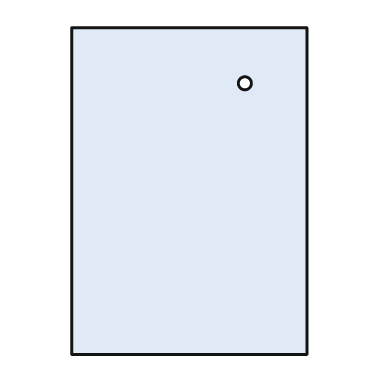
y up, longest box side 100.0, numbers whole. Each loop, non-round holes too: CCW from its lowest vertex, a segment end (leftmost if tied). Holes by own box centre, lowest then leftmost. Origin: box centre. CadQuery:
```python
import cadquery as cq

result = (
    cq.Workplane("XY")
    .moveTo(-36.0, -50.0)
    .lineTo(36.0, -50.0)
    .lineTo(36.0, 50.0)
    .lineTo(-36.0, 50.0)
    .close()
    .moveTo(17.0, 33.0)
    .circle(2.0)
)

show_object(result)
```